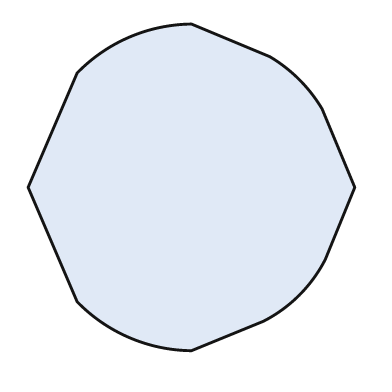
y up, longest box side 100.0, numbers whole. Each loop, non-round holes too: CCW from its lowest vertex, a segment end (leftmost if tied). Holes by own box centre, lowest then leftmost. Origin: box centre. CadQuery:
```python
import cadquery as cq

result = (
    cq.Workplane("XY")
    .moveTo(0.0, -50.0)
    .lineTo(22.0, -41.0)
    .threePointArc((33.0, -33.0), (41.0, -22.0))
    .lineTo(50.0, 0.0)
    .lineTo(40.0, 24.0)
    .threePointArc((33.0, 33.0), (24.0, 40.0))
    .lineTo(0.0, 50.0)
    .threePointArc((-19.0, 46.0), (-35.0, 35.0))
    .lineTo(-50.0, 0.0)
    .lineTo(-35.0, -35.0)
    .threePointArc((-19.0, -46.0), (0.0, -50.0))
    .close()
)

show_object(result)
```